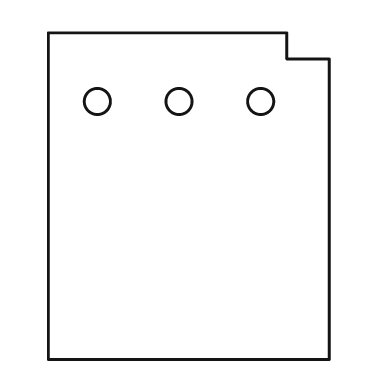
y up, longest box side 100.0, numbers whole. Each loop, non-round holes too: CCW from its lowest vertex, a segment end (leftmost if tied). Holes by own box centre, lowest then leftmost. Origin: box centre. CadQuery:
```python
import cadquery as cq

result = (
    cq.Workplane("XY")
    .moveTo(-43.0, -50.0)
    .lineTo(43.0, -50.0)
    .lineTo(43.0, 42.0)
    .lineTo(30.0, 42.0)
    .lineTo(30.0, 50.0)
    .lineTo(-43.0, 50.0)
    .close()
    .moveTo(-28.0, 29.0)
    .circle(4.0)
    .moveTo(-3.0, 29.0)
    .circle(4.0)
    .moveTo(22.0, 29.0)
    .circle(4.0)
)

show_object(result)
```